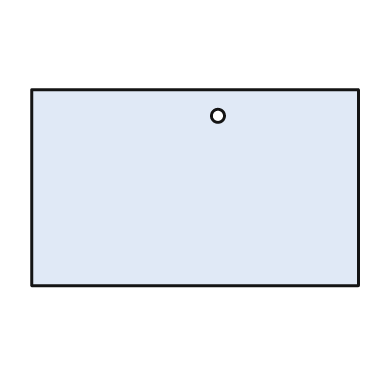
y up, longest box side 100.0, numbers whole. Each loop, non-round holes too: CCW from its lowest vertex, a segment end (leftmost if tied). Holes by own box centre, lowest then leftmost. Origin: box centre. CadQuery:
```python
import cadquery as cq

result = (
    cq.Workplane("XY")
    .moveTo(-50.0, -30.0)
    .lineTo(50.0, -30.0)
    .lineTo(50.0, 30.0)
    .lineTo(-50.0, 30.0)
    .close()
    .moveTo(7.0, 22.0)
    .circle(2.0)
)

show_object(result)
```